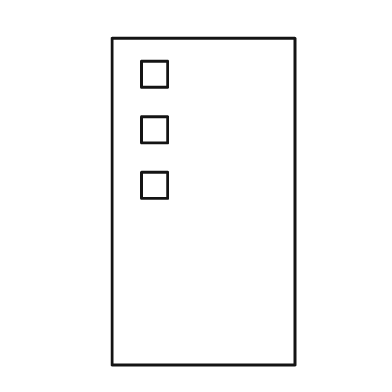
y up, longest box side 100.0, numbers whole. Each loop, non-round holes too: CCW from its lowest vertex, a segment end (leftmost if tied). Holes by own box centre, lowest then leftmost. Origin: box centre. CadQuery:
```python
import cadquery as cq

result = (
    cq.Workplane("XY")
    .moveTo(-28.0, -50.0)
    .lineTo(28.0, -50.0)
    .lineTo(28.0, 50.0)
    .lineTo(-28.0, 50.0)
    .close()
    .moveTo(-19.0, 1.0)
    .lineTo(-11.0, 1.0)
    .lineTo(-11.0, 9.0)
    .lineTo(-19.0, 9.0)
    .close()
    .moveTo(-19.0, 18.0)
    .lineTo(-11.0, 18.0)
    .lineTo(-11.0, 26.0)
    .lineTo(-19.0, 26.0)
    .close()
    .moveTo(-19.0, 35.0)
    .lineTo(-11.0, 35.0)
    .lineTo(-11.0, 43.0)
    .lineTo(-19.0, 43.0)
    .close()
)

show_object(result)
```